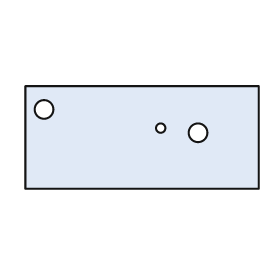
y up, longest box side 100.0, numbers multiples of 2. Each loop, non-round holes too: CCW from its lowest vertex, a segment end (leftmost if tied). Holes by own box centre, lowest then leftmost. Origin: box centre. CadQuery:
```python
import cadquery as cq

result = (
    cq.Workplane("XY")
    .moveTo(-50.0, -22.0)
    .lineTo(50.0, -22.0)
    .lineTo(50.0, 22.0)
    .lineTo(-50.0, 22.0)
    .close()
    .moveTo(24.0, 2.0)
    .circle(4.0)
    .moveTo(8.0, 4.0)
    .circle(2.0)
    .moveTo(-42.0, 12.0)
    .circle(4.0)
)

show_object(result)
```